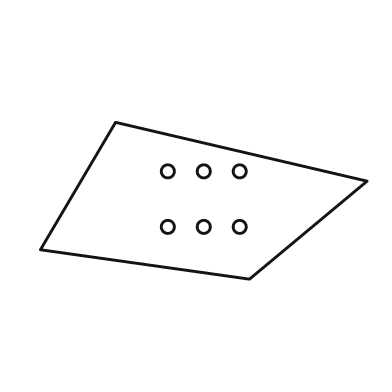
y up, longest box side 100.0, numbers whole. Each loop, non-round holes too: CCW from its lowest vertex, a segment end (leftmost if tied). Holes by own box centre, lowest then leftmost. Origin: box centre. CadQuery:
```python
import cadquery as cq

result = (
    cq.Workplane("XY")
    .moveTo(14.0, -24.0)
    .lineTo(50.0, 6.0)
    .lineTo(-27.0, 24.0)
    .lineTo(-50.0, -15.0)
    .close()
    .moveTo(-11.0, -8.0)
    .circle(2.0)
    .moveTo(0.0, -8.0)
    .circle(2.0)
    .moveTo(11.0, -8.0)
    .circle(2.0)
    .moveTo(-11.0, 9.0)
    .circle(2.0)
    .moveTo(0.0, 9.0)
    .circle(2.0)
    .moveTo(11.0, 9.0)
    .circle(2.0)
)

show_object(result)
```